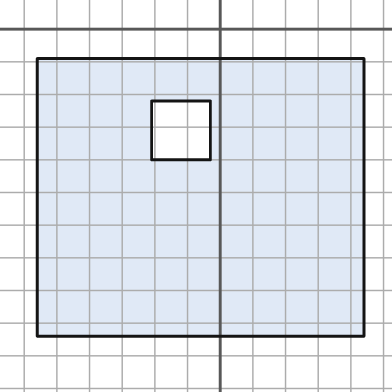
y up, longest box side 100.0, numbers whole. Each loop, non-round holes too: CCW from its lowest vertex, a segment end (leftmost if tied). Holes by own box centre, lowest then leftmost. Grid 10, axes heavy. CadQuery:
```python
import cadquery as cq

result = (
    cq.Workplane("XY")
    .moveTo(-56.0, -94.0)
    .lineTo(44.0, -94.0)
    .lineTo(44.0, -9.0)
    .lineTo(-56.0, -9.0)
    .close()
    .moveTo(-21.0, -40.0)
    .lineTo(-3.0, -40.0)
    .lineTo(-3.0, -22.0)
    .lineTo(-21.0, -22.0)
    .close()
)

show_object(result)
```